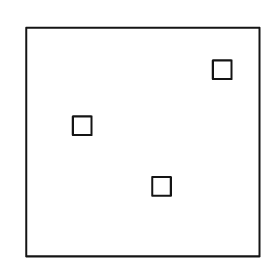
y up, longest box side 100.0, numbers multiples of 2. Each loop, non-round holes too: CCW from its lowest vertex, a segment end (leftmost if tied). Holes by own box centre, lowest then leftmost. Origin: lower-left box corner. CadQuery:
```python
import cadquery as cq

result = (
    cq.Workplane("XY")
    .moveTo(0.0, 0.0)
    .lineTo(100.0, 0.0)
    .lineTo(100.0, 98.0)
    .lineTo(0.0, 98.0)
    .close()
    .moveTo(54.0, 26.0)
    .lineTo(62.0, 26.0)
    .lineTo(62.0, 34.0)
    .lineTo(54.0, 34.0)
    .close()
    .moveTo(20.0, 52.0)
    .lineTo(28.0, 52.0)
    .lineTo(28.0, 60.0)
    .lineTo(20.0, 60.0)
    .close()
    .moveTo(80.0, 76.0)
    .lineTo(88.0, 76.0)
    .lineTo(88.0, 84.0)
    .lineTo(80.0, 84.0)
    .close()
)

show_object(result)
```